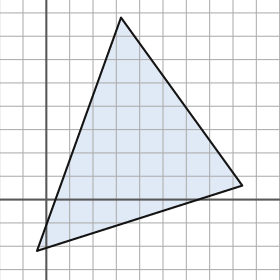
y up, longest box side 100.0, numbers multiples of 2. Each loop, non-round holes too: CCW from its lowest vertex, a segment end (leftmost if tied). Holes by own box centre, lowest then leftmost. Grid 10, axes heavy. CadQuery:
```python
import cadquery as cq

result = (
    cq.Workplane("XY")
    .moveTo(-4.0, -22.0)
    .lineTo(84.0, 6.0)
    .lineTo(32.0, 78.0)
    .close()
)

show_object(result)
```